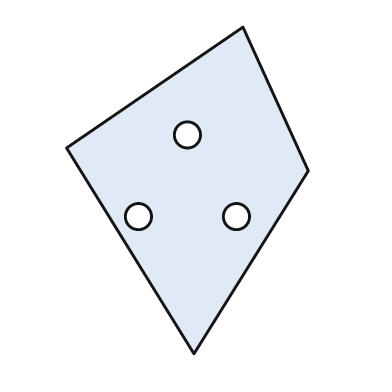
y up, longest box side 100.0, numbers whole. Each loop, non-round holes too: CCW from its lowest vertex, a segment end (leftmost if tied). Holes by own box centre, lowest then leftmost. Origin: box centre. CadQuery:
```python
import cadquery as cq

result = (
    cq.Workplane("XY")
    .moveTo(2.0, -50.0)
    .lineTo(37.0, 6.0)
    .lineTo(17.0, 50.0)
    .lineTo(-37.0, 13.0)
    .close()
    .moveTo(-15.0, -8.0)
    .circle(4.0)
    .moveTo(15.0, -8.0)
    .circle(4.0)
    .moveTo(0.0, 17.0)
    .circle(4.0)
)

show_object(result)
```